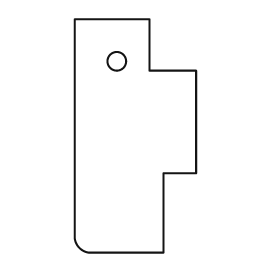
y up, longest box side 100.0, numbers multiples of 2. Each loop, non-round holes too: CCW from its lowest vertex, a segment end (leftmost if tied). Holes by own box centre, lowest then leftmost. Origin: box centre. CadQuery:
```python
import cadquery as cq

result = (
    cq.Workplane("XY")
    .moveTo(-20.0, -50.0)
    .lineTo(12.0, -50.0)
    .lineTo(12.0, -16.0)
    .lineTo(26.0, -16.0)
    .lineTo(26.0, 28.0)
    .lineTo(6.0, 28.0)
    .lineTo(6.0, 50.0)
    .lineTo(-26.0, 50.0)
    .lineTo(-26.0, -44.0)
    .threePointArc((-24.0, -48.0), (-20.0, -50.0))
    .close()
    .moveTo(-8.0, 32.0)
    .circle(4.0)
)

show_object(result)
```